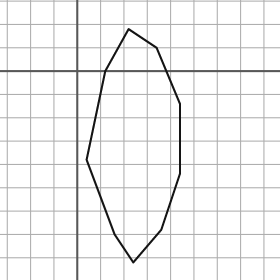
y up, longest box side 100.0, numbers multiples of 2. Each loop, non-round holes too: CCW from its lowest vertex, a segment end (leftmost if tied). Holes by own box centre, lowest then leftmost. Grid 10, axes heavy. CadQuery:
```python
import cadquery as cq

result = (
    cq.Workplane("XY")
    .moveTo(24.0, -82.0)
    .lineTo(36.0, -68.0)
    .lineTo(44.0, -44.0)
    .lineTo(44.0, -14.0)
    .lineTo(34.0, 10.0)
    .lineTo(22.0, 18.0)
    .lineTo(12.0, 0.0)
    .lineTo(4.0, -38.0)
    .lineTo(16.0, -70.0)
    .close()
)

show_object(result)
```